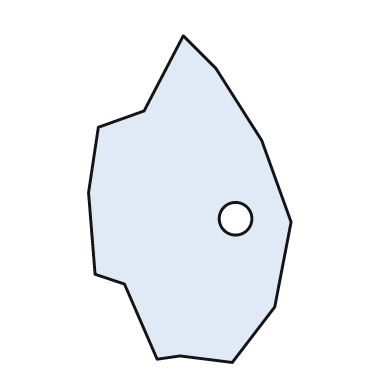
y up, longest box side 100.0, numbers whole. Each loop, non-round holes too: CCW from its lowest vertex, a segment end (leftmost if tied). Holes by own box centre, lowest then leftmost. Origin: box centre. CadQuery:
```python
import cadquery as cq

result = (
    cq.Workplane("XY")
    .moveTo(13.0, -50.0)
    .lineTo(26.0, -33.0)
    .lineTo(31.0, -7.0)
    .lineTo(22.0, 18.0)
    .lineTo(8.0, 40.0)
    .lineTo(-2.0, 50.0)
    .lineTo(-14.0, 27.0)
    .lineTo(-28.0, 22.0)
    .lineTo(-31.0, 2.0)
    .lineTo(-29.0, -23.0)
    .lineTo(-20.0, -26.0)
    .lineTo(-10.0, -49.0)
    .lineTo(-3.0, -48.0)
    .close()
    .moveTo(14.0, -6.0)
    .circle(5.0)
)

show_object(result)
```